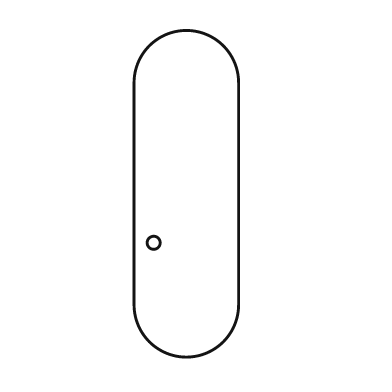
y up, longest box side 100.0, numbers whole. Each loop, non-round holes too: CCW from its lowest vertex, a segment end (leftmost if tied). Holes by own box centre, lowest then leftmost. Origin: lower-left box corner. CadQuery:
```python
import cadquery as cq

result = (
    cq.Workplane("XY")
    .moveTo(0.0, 16.0)
    .threePointArc((16.0, 0.0), (32.0, 16.0))
    .lineTo(32.0, 84.0)
    .threePointArc((16.0, 100.0), (0.0, 84.0))
    .close()
    .moveTo(6.0, 35.0)
    .circle(2.0)
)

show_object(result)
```